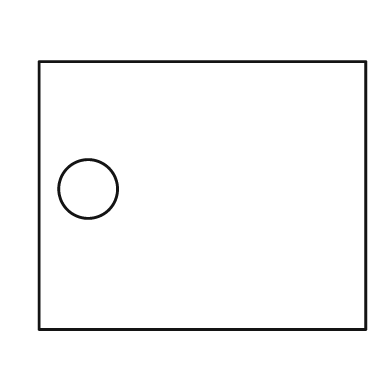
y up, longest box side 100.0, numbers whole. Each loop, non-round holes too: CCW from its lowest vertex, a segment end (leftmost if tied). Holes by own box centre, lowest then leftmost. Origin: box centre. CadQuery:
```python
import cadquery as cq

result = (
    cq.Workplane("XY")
    .moveTo(-50.0, -41.0)
    .lineTo(50.0, -41.0)
    .lineTo(50.0, 41.0)
    .lineTo(-50.0, 41.0)
    .close()
    .moveTo(-35.0, 2.0)
    .circle(9.0)
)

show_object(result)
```